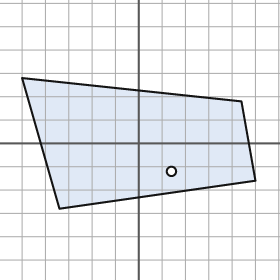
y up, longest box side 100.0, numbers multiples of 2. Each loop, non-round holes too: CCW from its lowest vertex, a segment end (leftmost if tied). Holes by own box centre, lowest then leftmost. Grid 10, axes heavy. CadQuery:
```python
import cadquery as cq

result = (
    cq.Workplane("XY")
    .moveTo(-34.0, -28.0)
    .lineTo(50.0, -16.0)
    .lineTo(44.0, 18.0)
    .lineTo(-50.0, 28.0)
    .close()
    .moveTo(14.0, -12.0)
    .circle(2.0)
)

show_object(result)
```